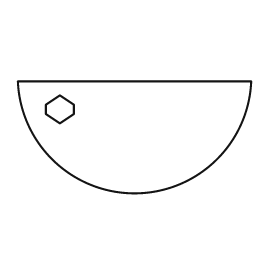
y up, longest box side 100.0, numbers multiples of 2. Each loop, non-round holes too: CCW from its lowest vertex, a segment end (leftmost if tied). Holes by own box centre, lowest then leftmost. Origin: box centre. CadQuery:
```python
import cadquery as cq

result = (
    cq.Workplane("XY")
    .moveTo(-50.0, 24.0)
    .threePointArc((0.0, -24.0), (50.0, 24.0))
    .close()
    .moveTo(-32.0, 6.0)
    .lineTo(-26.0, 10.0)
    .lineTo(-26.0, 14.0)
    .lineTo(-32.0, 18.0)
    .lineTo(-38.0, 14.0)
    .lineTo(-38.0, 10.0)
    .close()
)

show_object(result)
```